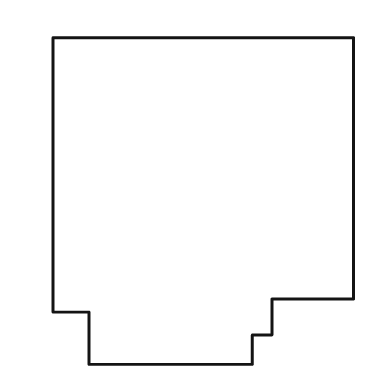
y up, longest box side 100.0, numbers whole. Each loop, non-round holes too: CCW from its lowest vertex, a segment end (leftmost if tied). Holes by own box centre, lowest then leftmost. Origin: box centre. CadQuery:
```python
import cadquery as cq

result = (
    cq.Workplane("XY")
    .moveTo(-35.0, -50.0)
    .lineTo(15.0, -50.0)
    .lineTo(15.0, -41.0)
    .lineTo(21.0, -41.0)
    .lineTo(21.0, -30.0)
    .lineTo(46.0, -30.0)
    .lineTo(46.0, 50.0)
    .lineTo(-46.0, 50.0)
    .lineTo(-46.0, -34.0)
    .lineTo(-35.0, -34.0)
    .close()
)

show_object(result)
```